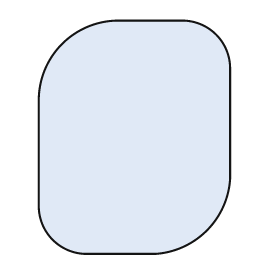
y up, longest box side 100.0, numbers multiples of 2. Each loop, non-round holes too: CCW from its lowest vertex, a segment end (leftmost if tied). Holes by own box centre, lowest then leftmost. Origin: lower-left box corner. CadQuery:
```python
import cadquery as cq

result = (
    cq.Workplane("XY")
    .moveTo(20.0, 0.0)
    .lineTo(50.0, 0.0)
    .threePointArc((72.0, 10.0), (82.0, 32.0))
    .lineTo(82.0, 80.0)
    .threePointArc((76.0, 94.0), (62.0, 100.0))
    .lineTo(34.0, 100.0)
    .threePointArc((10.0, 90.0), (0.0, 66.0))
    .lineTo(0.0, 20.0)
    .threePointArc((6.0, 6.0), (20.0, 0.0))
    .close()
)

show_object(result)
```